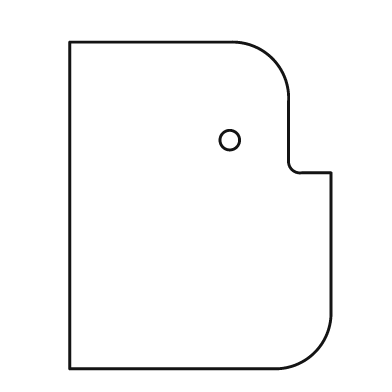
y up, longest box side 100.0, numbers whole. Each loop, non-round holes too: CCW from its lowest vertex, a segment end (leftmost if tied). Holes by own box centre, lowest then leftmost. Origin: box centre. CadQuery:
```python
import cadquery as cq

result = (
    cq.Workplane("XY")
    .moveTo(-40.0, -50.0)
    .lineTo(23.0, -50.0)
    .threePointArc((35.0, -45.0), (40.0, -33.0))
    .lineTo(40.0, 10.0)
    .lineTo(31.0, 10.0)
    .threePointArc((28.0, 11.0), (27.0, 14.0))
    .lineTo(27.0, 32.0)
    .threePointArc((22.0, 45.0), (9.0, 50.0))
    .lineTo(-40.0, 50.0)
    .close()
    .moveTo(9.0, 20.0)
    .circle(3.0)
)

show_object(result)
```